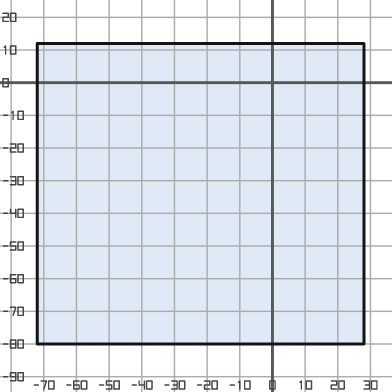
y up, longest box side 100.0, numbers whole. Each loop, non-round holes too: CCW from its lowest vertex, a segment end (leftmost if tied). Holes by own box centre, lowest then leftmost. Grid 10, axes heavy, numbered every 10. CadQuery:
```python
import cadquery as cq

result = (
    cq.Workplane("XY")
    .moveTo(-72.0, -80.0)
    .lineTo(28.0, -80.0)
    .lineTo(28.0, 12.0)
    .lineTo(-72.0, 12.0)
    .close()
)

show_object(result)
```